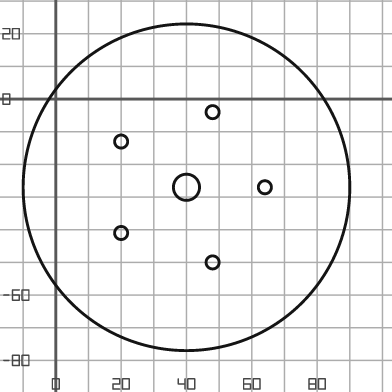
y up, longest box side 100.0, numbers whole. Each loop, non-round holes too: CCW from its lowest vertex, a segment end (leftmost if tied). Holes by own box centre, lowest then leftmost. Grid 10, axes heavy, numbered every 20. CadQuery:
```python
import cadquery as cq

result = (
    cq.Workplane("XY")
    .moveTo(40.0, -27.0)
    .circle(50.0)
    .moveTo(48.0, -50.0)
    .circle(2.0)
    .moveTo(20.0, -41.0)
    .circle(2.0)
    .moveTo(40.0, -27.0)
    .circle(4.0)
    .moveTo(64.0, -27.0)
    .circle(2.0)
    .moveTo(20.0, -13.0)
    .circle(2.0)
    .moveTo(48.0, -4.0)
    .circle(2.0)
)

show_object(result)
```